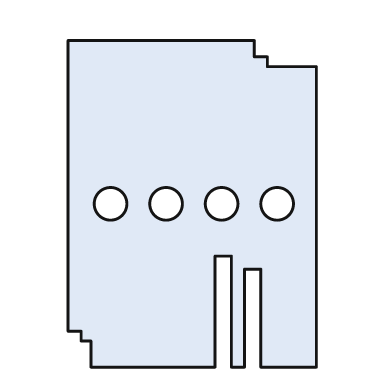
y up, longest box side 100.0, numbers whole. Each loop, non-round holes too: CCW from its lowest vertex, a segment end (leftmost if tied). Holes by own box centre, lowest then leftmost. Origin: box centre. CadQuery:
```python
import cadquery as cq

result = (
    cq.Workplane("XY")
    .moveTo(-31.0, -50.0)
    .lineTo(7.0, -50.0)
    .lineTo(7.0, -16.0)
    .lineTo(12.0, -16.0)
    .lineTo(12.0, -50.0)
    .lineTo(16.0, -50.0)
    .lineTo(16.0, -20.0)
    .lineTo(21.0, -20.0)
    .lineTo(21.0, -50.0)
    .lineTo(38.0, -50.0)
    .lineTo(38.0, 42.0)
    .lineTo(23.0, 42.0)
    .lineTo(23.0, 45.0)
    .lineTo(19.0, 45.0)
    .lineTo(19.0, 50.0)
    .lineTo(-38.0, 50.0)
    .lineTo(-38.0, -39.0)
    .lineTo(-34.0, -39.0)
    .lineTo(-34.0, -42.0)
    .lineTo(-31.0, -42.0)
    .close()
    .moveTo(-25.0, 0.0)
    .circle(5.0)
    .moveTo(-8.0, 0.0)
    .circle(5.0)
    .moveTo(9.0, 0.0)
    .circle(5.0)
    .moveTo(26.0, 0.0)
    .circle(5.0)
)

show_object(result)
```